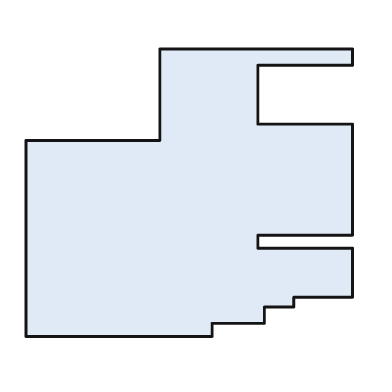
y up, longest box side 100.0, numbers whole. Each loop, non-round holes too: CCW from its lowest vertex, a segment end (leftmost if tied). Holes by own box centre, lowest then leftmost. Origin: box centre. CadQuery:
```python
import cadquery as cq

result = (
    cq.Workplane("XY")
    .moveTo(-50.0, -44.0)
    .lineTo(7.0, -44.0)
    .lineTo(7.0, -40.0)
    .lineTo(23.0, -40.0)
    .lineTo(23.0, -35.0)
    .lineTo(32.0, -35.0)
    .lineTo(32.0, -32.0)
    .lineTo(50.0, -32.0)
    .lineTo(50.0, -17.0)
    .lineTo(21.0, -17.0)
    .lineTo(21.0, -13.0)
    .lineTo(50.0, -13.0)
    .lineTo(50.0, 21.0)
    .lineTo(21.0, 21.0)
    .lineTo(21.0, 39.0)
    .lineTo(50.0, 39.0)
    .lineTo(50.0, 44.0)
    .lineTo(-9.0, 44.0)
    .lineTo(-9.0, 16.0)
    .lineTo(-50.0, 16.0)
    .close()
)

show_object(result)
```